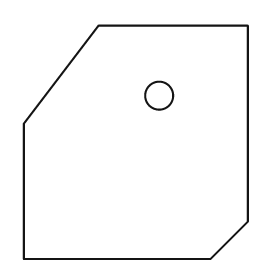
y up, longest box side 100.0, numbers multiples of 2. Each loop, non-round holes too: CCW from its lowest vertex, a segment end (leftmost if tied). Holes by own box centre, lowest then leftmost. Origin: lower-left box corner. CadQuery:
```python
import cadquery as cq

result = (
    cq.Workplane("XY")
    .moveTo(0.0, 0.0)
    .lineTo(80.0, 0.0)
    .lineTo(96.0, 16.0)
    .lineTo(96.0, 100.0)
    .lineTo(32.0, 100.0)
    .lineTo(0.0, 58.0)
    .close()
    .moveTo(58.0, 70.0)
    .circle(6.0)
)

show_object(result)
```